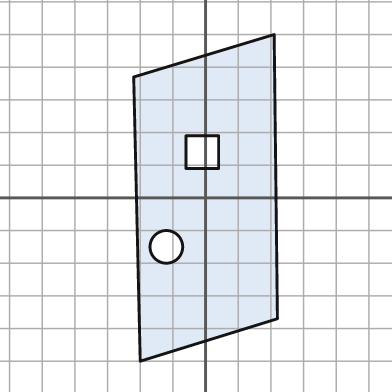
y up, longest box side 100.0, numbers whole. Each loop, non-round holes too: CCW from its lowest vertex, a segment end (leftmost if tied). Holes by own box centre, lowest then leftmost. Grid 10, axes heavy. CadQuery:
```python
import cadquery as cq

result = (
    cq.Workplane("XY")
    .moveTo(-20.0, -50.0)
    .lineTo(22.0, -37.0)
    .lineTo(21.0, 50.0)
    .lineTo(-22.0, 37.0)
    .close()
    .moveTo(-12.0, -15.0)
    .circle(5.0)
    .moveTo(-6.0, 9.0)
    .lineTo(4.0, 9.0)
    .lineTo(4.0, 19.0)
    .lineTo(-6.0, 19.0)
    .close()
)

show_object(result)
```